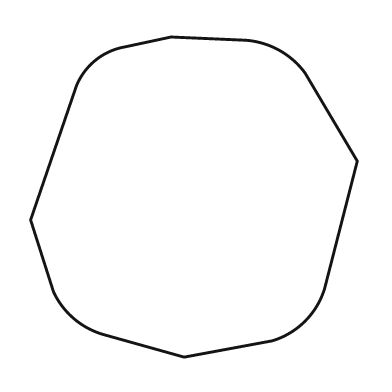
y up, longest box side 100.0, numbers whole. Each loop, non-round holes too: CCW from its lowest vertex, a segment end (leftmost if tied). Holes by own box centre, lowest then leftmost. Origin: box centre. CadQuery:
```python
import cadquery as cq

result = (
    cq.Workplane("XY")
    .moveTo(-3.0, -49.0)
    .lineTo(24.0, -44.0)
    .threePointArc((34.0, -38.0), (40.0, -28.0))
    .lineTo(50.0, 11.0)
    .lineTo(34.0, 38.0)
    .threePointArc((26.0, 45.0), (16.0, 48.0))
    .lineTo(-7.0, 49.0)
    .lineTo(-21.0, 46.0)
    .threePointArc((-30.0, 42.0), (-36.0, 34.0))
    .lineTo(-50.0, -7.0)
    .lineTo(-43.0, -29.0)
    .threePointArc((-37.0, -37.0), (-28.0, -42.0))
    .close()
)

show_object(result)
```